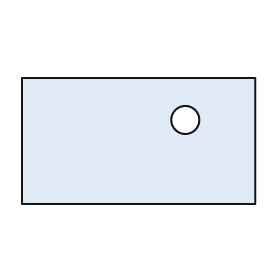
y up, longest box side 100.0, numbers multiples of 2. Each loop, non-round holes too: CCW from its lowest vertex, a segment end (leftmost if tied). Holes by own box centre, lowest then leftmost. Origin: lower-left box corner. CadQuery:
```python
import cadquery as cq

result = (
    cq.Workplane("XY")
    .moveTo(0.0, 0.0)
    .lineTo(100.0, 0.0)
    .lineTo(100.0, 54.0)
    .lineTo(0.0, 54.0)
    .close()
    .moveTo(70.0, 36.0)
    .circle(6.0)
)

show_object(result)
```